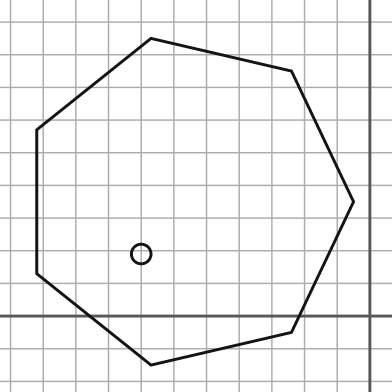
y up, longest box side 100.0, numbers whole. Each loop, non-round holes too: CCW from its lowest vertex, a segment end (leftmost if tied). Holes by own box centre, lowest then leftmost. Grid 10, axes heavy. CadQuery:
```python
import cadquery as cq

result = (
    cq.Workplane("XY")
    .moveTo(-67.0, -15.0)
    .lineTo(-24.0, -5.0)
    .lineTo(-5.0, 35.0)
    .lineTo(-24.0, 75.0)
    .lineTo(-67.0, 85.0)
    .lineTo(-102.0, 57.0)
    .lineTo(-102.0, 13.0)
    .close()
    .moveTo(-70.0, 19.0)
    .circle(3.0)
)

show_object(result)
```